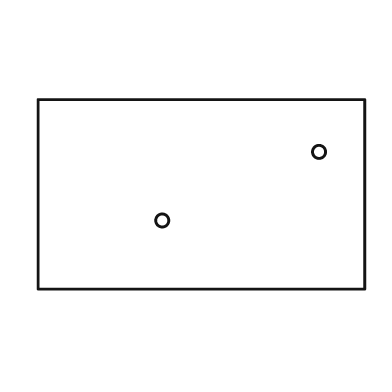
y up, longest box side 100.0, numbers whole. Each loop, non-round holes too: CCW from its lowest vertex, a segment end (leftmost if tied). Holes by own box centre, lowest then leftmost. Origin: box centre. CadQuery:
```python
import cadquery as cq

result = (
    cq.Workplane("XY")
    .moveTo(-50.0, -29.0)
    .lineTo(50.0, -29.0)
    .lineTo(50.0, 29.0)
    .lineTo(-50.0, 29.0)
    .close()
    .moveTo(-12.0, -8.0)
    .circle(2.0)
    .moveTo(36.0, 13.0)
    .circle(2.0)
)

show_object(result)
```